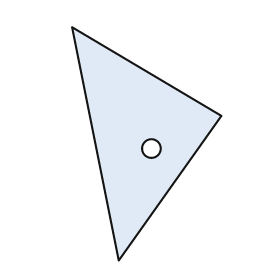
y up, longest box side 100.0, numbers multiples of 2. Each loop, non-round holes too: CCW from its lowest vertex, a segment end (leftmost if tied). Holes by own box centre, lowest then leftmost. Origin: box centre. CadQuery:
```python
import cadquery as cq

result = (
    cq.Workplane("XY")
    .moveTo(-12.0, -50.0)
    .lineTo(32.0, 12.0)
    .lineTo(-32.0, 50.0)
    .close()
    .moveTo(2.0, -2.0)
    .circle(4.0)
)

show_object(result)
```